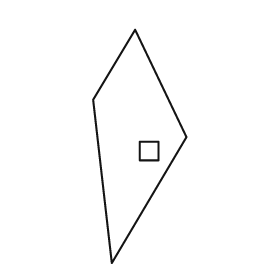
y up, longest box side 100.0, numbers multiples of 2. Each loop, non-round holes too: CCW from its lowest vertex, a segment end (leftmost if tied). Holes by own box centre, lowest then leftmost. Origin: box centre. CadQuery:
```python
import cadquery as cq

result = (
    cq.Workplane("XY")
    .moveTo(-12.0, -50.0)
    .lineTo(20.0, 4.0)
    .lineTo(-2.0, 50.0)
    .lineTo(-20.0, 20.0)
    .close()
    .moveTo(0.0, -6.0)
    .lineTo(8.0, -6.0)
    .lineTo(8.0, 2.0)
    .lineTo(0.0, 2.0)
    .close()
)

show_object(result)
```